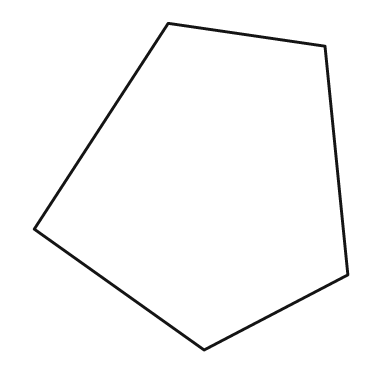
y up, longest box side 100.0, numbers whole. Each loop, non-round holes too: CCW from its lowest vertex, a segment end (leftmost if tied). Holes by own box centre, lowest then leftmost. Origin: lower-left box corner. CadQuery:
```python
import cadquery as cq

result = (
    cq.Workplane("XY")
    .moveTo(52.0, 0.0)
    .lineTo(96.0, 23.0)
    .lineTo(89.0, 93.0)
    .lineTo(41.0, 100.0)
    .lineTo(0.0, 37.0)
    .close()
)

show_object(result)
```